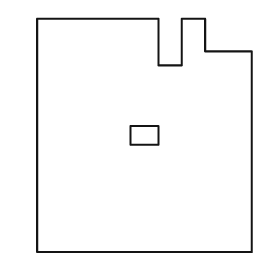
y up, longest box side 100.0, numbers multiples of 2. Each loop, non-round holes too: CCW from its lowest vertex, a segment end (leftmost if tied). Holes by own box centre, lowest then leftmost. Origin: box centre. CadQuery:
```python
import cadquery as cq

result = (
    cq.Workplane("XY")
    .moveTo(-46.0, -50.0)
    .lineTo(46.0, -50.0)
    .lineTo(46.0, 36.0)
    .lineTo(26.0, 36.0)
    .lineTo(26.0, 50.0)
    .lineTo(16.0, 50.0)
    .lineTo(16.0, 30.0)
    .lineTo(6.0, 30.0)
    .lineTo(6.0, 50.0)
    .lineTo(-46.0, 50.0)
    .close()
    .moveTo(-6.0, -4.0)
    .lineTo(6.0, -4.0)
    .lineTo(6.0, 4.0)
    .lineTo(-6.0, 4.0)
    .close()
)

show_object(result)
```